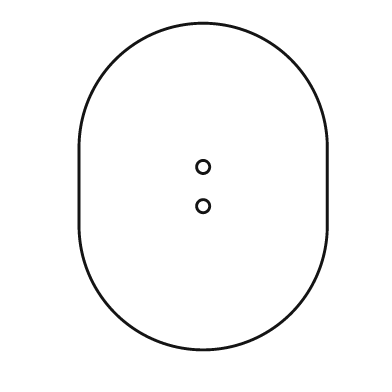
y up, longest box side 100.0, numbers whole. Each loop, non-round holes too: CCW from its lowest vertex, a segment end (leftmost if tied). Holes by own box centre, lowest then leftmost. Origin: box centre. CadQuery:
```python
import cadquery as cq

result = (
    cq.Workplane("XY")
    .moveTo(-38.0, -12.0)
    .threePointArc((0.0, -50.0), (38.0, -12.0))
    .lineTo(38.0, 12.0)
    .threePointArc((0.0, 50.0), (-38.0, 12.0))
    .close()
    .moveTo(0.0, -6.0)
    .circle(2.0)
    .moveTo(0.0, 6.0)
    .circle(2.0)
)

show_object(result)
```